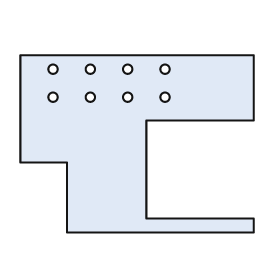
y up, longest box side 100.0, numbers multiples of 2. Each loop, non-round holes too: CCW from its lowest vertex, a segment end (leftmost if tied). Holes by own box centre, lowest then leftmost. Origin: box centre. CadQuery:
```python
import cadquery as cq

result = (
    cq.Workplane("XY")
    .moveTo(-30.0, -38.0)
    .lineTo(50.0, -38.0)
    .lineTo(50.0, -32.0)
    .lineTo(4.0, -32.0)
    .lineTo(4.0, 10.0)
    .lineTo(50.0, 10.0)
    .lineTo(50.0, 38.0)
    .lineTo(-50.0, 38.0)
    .lineTo(-50.0, -8.0)
    .lineTo(-30.0, -8.0)
    .close()
    .moveTo(-36.0, 20.0)
    .circle(2.0)
    .moveTo(-20.0, 20.0)
    .circle(2.0)
    .moveTo(-4.0, 20.0)
    .circle(2.0)
    .moveTo(12.0, 20.0)
    .circle(2.0)
    .moveTo(-36.0, 32.0)
    .circle(2.0)
    .moveTo(-20.0, 32.0)
    .circle(2.0)
    .moveTo(-4.0, 32.0)
    .circle(2.0)
    .moveTo(12.0, 32.0)
    .circle(2.0)
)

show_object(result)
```